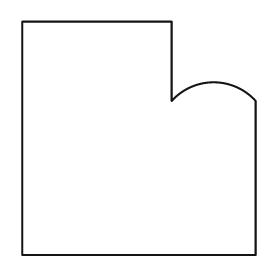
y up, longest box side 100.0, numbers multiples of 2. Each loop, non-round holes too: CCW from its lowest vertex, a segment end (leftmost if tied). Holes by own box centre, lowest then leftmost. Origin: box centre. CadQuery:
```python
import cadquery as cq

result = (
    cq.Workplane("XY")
    .moveTo(-50.0, -50.0)
    .lineTo(50.0, -50.0)
    .lineTo(50.0, 16.0)
    .threePointArc((32.0, 24.0), (14.0, 16.0))
    .lineTo(14.0, 50.0)
    .lineTo(-50.0, 50.0)
    .close()
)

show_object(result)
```